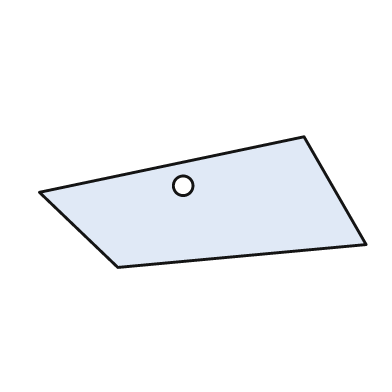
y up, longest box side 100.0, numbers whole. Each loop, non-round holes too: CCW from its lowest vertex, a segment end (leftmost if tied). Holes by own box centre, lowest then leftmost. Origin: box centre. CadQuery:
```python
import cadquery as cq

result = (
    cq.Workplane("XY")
    .moveTo(-26.0, -20.0)
    .lineTo(50.0, -13.0)
    .lineTo(31.0, 20.0)
    .lineTo(-50.0, 3.0)
    .close()
    .moveTo(-6.0, 5.0)
    .circle(3.0)
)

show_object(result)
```